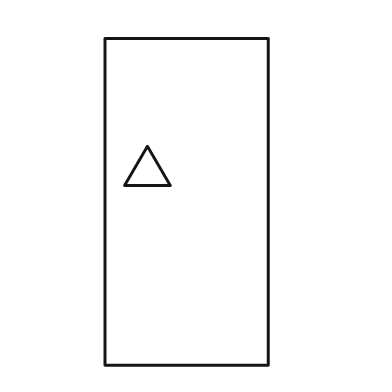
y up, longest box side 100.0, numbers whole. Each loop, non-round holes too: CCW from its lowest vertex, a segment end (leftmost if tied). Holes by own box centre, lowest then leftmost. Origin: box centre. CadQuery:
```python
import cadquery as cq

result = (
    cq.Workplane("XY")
    .moveTo(-25.0, -50.0)
    .lineTo(25.0, -50.0)
    .lineTo(25.0, 50.0)
    .lineTo(-25.0, 50.0)
    .close()
    .moveTo(-19.0, 5.0)
    .lineTo(-5.0, 5.0)
    .lineTo(-12.0, 17.0)
    .close()
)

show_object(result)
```